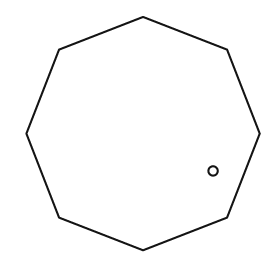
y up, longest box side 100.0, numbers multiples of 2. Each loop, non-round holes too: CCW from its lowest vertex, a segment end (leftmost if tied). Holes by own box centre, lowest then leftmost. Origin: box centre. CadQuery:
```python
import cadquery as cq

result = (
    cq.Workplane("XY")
    .moveTo(0.0, -50.0)
    .lineTo(36.0, -36.0)
    .lineTo(50.0, 0.0)
    .lineTo(36.0, 36.0)
    .lineTo(0.0, 50.0)
    .lineTo(-36.0, 36.0)
    .lineTo(-50.0, 0.0)
    .lineTo(-36.0, -36.0)
    .close()
    .moveTo(30.0, -16.0)
    .circle(2.0)
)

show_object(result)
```